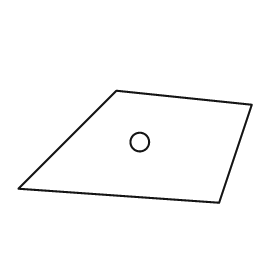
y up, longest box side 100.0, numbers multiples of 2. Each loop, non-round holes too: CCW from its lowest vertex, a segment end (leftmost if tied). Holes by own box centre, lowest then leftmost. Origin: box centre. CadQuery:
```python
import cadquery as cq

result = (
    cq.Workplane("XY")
    .moveTo(36.0, -24.0)
    .lineTo(50.0, 18.0)
    .lineTo(-8.0, 24.0)
    .lineTo(-50.0, -18.0)
    .close()
    .moveTo(2.0, 2.0)
    .circle(4.0)
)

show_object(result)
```